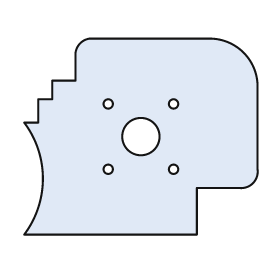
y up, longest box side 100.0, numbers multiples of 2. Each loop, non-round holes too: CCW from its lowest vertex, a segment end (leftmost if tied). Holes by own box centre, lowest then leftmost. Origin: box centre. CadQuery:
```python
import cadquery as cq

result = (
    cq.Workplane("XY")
    .moveTo(-50.0, -42.0)
    .lineTo(24.0, -42.0)
    .lineTo(24.0, -22.0)
    .lineTo(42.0, -22.0)
    .threePointArc((48.0, -20.0), (50.0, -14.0))
    .lineTo(50.0, 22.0)
    .threePointArc((44.0, 36.0), (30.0, 42.0))
    .lineTo(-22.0, 42.0)
    .threePointArc((-26.0, 40.0), (-28.0, 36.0))
    .lineTo(-28.0, 24.0)
    .lineTo(-38.0, 24.0)
    .lineTo(-38.0, 16.0)
    .lineTo(-44.0, 16.0)
    .lineTo(-44.0, 6.0)
    .lineTo(-50.0, 6.0)
    .threePointArc((-42.0, -18.0), (-50.0, -42.0))
    .close()
    .moveTo(-14.0, -14.0)
    .circle(2.0)
    .moveTo(14.0, -14.0)
    .circle(2.0)
    .moveTo(0.0, 0.0)
    .circle(8.0)
    .moveTo(-14.0, 14.0)
    .circle(2.0)
    .moveTo(14.0, 14.0)
    .circle(2.0)
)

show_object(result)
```